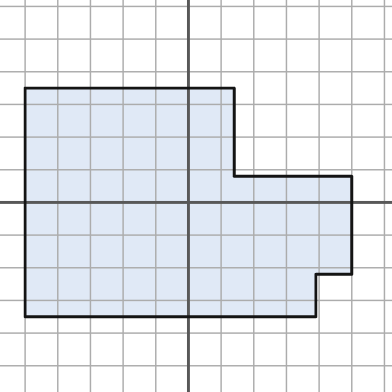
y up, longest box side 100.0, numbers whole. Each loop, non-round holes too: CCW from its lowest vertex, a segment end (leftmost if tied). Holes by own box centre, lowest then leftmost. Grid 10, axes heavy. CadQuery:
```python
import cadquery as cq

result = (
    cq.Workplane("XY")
    .moveTo(-50.0, -35.0)
    .lineTo(39.0, -35.0)
    .lineTo(39.0, -22.0)
    .lineTo(50.0, -22.0)
    .lineTo(50.0, 8.0)
    .lineTo(14.0, 8.0)
    .lineTo(14.0, 35.0)
    .lineTo(-50.0, 35.0)
    .close()
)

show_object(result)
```